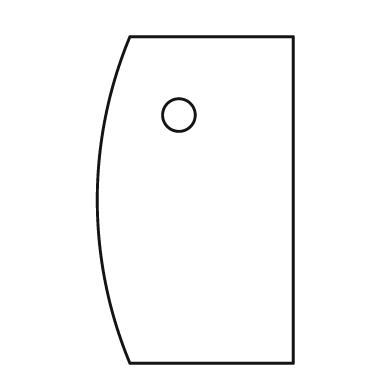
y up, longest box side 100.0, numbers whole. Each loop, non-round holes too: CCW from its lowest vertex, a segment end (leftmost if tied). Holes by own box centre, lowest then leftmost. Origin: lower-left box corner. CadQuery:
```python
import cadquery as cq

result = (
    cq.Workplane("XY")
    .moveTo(10.0, 0.0)
    .lineTo(60.0, 0.0)
    .lineTo(60.0, 100.0)
    .lineTo(10.0, 100.0)
    .threePointArc((0.0, 50.0), (10.0, 0.0))
    .close()
    .moveTo(25.0, 76.0)
    .circle(5.0)
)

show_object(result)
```